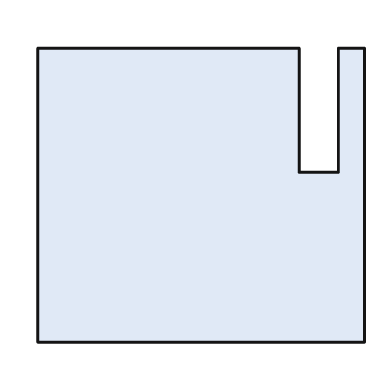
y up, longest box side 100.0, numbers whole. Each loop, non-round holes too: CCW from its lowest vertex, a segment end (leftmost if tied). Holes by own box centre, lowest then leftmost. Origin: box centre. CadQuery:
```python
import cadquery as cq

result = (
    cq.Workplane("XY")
    .moveTo(-50.0, -45.0)
    .lineTo(50.0, -45.0)
    .lineTo(50.0, 45.0)
    .lineTo(42.0, 45.0)
    .lineTo(42.0, 7.0)
    .lineTo(30.0, 7.0)
    .lineTo(30.0, 45.0)
    .lineTo(-50.0, 45.0)
    .close()
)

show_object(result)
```